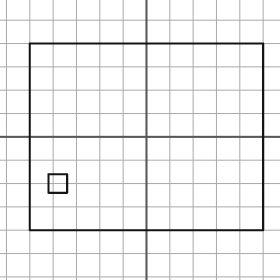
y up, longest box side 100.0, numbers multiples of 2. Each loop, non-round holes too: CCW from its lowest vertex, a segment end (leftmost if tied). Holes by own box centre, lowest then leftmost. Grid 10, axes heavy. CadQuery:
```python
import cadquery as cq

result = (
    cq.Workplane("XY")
    .moveTo(-50.0, -40.0)
    .lineTo(50.0, -40.0)
    .lineTo(50.0, 40.0)
    .lineTo(-50.0, 40.0)
    .close()
    .moveTo(-42.0, -24.0)
    .lineTo(-34.0, -24.0)
    .lineTo(-34.0, -16.0)
    .lineTo(-42.0, -16.0)
    .close()
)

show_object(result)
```